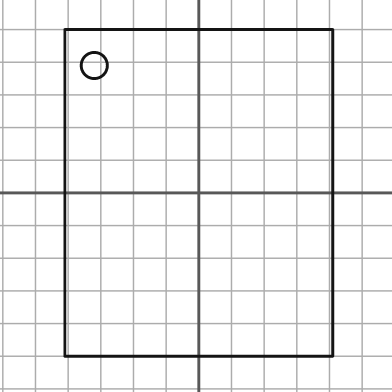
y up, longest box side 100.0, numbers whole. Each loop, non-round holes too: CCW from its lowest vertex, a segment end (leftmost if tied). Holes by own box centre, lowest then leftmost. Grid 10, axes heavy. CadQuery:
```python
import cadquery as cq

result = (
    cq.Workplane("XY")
    .moveTo(-41.0, -50.0)
    .lineTo(41.0, -50.0)
    .lineTo(41.0, 50.0)
    .lineTo(-41.0, 50.0)
    .close()
    .moveTo(-32.0, 39.0)
    .circle(4.0)
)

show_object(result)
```